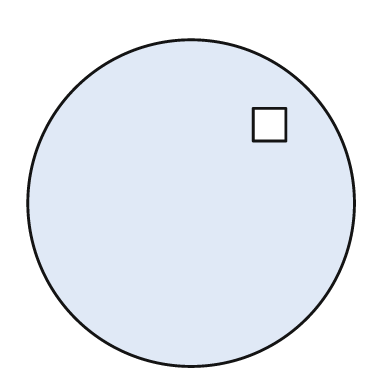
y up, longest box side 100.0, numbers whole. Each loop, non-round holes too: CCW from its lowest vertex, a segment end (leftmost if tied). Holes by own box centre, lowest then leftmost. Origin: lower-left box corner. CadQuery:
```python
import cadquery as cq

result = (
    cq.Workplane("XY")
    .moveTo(50.0, 50.0)
    .circle(50.0)
    .moveTo(69.0, 69.0)
    .lineTo(79.0, 69.0)
    .lineTo(79.0, 79.0)
    .lineTo(69.0, 79.0)
    .close()
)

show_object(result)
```